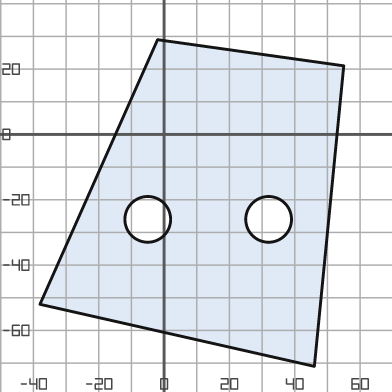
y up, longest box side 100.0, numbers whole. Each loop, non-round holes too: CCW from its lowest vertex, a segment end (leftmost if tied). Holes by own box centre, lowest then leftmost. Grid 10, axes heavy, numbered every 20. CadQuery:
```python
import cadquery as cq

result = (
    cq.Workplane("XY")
    .moveTo(46.0, -71.0)
    .lineTo(55.0, 21.0)
    .lineTo(-2.0, 29.0)
    .lineTo(-38.0, -52.0)
    .close()
    .moveTo(-5.0, -26.0)
    .circle(7.0)
    .moveTo(32.0, -26.0)
    .circle(7.0)
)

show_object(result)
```